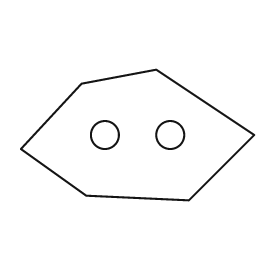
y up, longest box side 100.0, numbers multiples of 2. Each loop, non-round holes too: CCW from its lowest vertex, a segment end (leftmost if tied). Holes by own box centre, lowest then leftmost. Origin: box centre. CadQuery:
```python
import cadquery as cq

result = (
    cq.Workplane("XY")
    .moveTo(22.0, -28.0)
    .lineTo(50.0, 0.0)
    .lineTo(8.0, 28.0)
    .lineTo(-24.0, 22.0)
    .lineTo(-50.0, -6.0)
    .lineTo(-22.0, -26.0)
    .close()
    .moveTo(-14.0, 0.0)
    .circle(6.0)
    .moveTo(14.0, 0.0)
    .circle(6.0)
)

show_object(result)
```